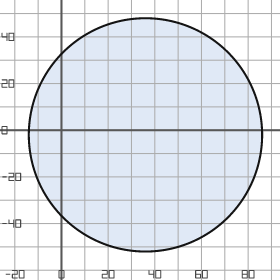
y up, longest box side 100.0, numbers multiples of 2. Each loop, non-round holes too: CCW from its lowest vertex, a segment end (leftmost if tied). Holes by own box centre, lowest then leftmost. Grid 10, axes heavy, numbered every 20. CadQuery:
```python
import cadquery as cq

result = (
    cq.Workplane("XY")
    .moveTo(36.0, -2.0)
    .circle(50.0)
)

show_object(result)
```